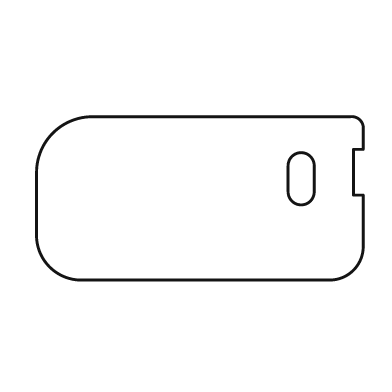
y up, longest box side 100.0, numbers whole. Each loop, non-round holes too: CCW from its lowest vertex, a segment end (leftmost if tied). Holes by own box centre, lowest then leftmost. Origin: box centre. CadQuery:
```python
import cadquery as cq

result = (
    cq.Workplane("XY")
    .moveTo(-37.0, -25.0)
    .lineTo(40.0, -25.0)
    .threePointArc((47.0, -22.0), (50.0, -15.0))
    .lineTo(50.0, 1.0)
    .lineTo(47.0, 1.0)
    .lineTo(47.0, 15.0)
    .lineTo(50.0, 15.0)
    .lineTo(50.0, 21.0)
    .threePointArc((49.0, 24.0), (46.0, 25.0))
    .lineTo(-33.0, 25.0)
    .threePointArc((-45.0, 20.0), (-50.0, 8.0))
    .lineTo(-50.0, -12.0)
    .threePointArc((-46.0, -21.0), (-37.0, -25.0))
    .close()
    .moveTo(27.0, 2.0)
    .threePointArc((31.0, -2.0), (35.0, 2.0))
    .lineTo(35.0, 10.0)
    .threePointArc((31.0, 14.0), (27.0, 10.0))
    .close()
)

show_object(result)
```